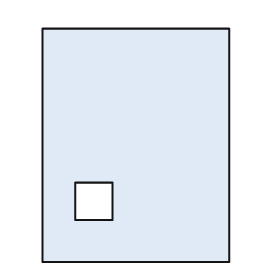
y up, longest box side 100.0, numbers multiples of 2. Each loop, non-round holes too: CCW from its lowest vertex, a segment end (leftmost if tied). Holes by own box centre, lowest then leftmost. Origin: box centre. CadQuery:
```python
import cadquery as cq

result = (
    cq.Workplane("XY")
    .moveTo(-40.0, -50.0)
    .lineTo(40.0, -50.0)
    .lineTo(40.0, 50.0)
    .lineTo(-40.0, 50.0)
    .close()
    .moveTo(-26.0, -32.0)
    .lineTo(-10.0, -32.0)
    .lineTo(-10.0, -16.0)
    .lineTo(-26.0, -16.0)
    .close()
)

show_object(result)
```